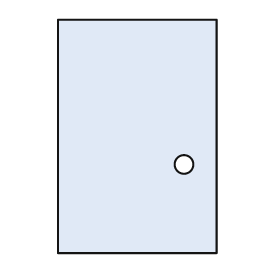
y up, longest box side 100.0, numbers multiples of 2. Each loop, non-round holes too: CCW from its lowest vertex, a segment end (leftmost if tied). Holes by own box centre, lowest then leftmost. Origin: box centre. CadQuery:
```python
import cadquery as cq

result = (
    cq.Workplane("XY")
    .moveTo(-34.0, -50.0)
    .lineTo(34.0, -50.0)
    .lineTo(34.0, 50.0)
    .lineTo(-34.0, 50.0)
    .close()
    .moveTo(20.0, -12.0)
    .circle(4.0)
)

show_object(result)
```